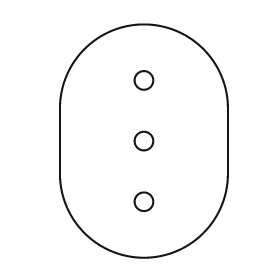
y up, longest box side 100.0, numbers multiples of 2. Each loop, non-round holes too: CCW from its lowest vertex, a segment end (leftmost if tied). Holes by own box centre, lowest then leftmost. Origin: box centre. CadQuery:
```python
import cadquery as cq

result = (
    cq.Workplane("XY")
    .moveTo(-36.0, -14.0)
    .threePointArc((0.0, -50.0), (36.0, -14.0))
    .lineTo(36.0, 14.0)
    .threePointArc((0.0, 50.0), (-36.0, 14.0))
    .close()
    .moveTo(0.0, -26.0)
    .circle(4.0)
    .moveTo(0.0, 0.0)
    .circle(4.0)
    .moveTo(0.0, 26.0)
    .circle(4.0)
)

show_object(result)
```